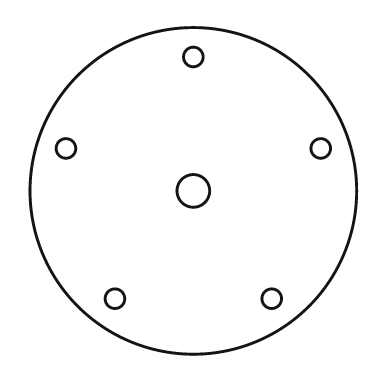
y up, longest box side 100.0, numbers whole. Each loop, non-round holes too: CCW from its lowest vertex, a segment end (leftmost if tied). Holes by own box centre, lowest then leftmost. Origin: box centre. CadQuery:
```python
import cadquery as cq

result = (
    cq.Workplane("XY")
    .moveTo(0.0, 0.0)
    .circle(50.0)
    .moveTo(-24.0, -33.0)
    .circle(3.0)
    .moveTo(24.0, -33.0)
    .circle(3.0)
    .moveTo(0.0, 0.0)
    .circle(5.0)
    .moveTo(-39.0, 13.0)
    .circle(3.0)
    .moveTo(39.0, 13.0)
    .circle(3.0)
    .moveTo(0.0, 41.0)
    .circle(3.0)
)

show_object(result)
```